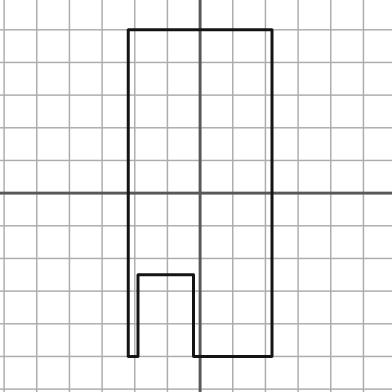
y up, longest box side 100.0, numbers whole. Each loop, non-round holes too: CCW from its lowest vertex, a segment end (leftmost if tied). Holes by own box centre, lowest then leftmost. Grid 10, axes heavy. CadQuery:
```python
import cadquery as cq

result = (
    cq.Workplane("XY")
    .moveTo(-22.0, -50.0)
    .lineTo(-19.0, -50.0)
    .lineTo(-19.0, -25.0)
    .lineTo(-2.0, -25.0)
    .lineTo(-2.0, -50.0)
    .lineTo(22.0, -50.0)
    .lineTo(22.0, 50.0)
    .lineTo(-22.0, 50.0)
    .close()
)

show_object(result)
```